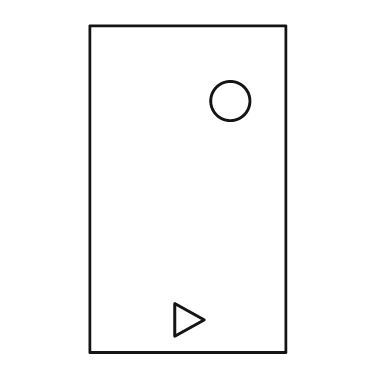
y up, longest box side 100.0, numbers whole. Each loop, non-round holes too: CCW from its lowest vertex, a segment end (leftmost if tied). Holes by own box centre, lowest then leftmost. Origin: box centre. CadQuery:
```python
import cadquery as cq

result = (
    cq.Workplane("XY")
    .moveTo(-30.0, -50.0)
    .lineTo(30.0, -50.0)
    .lineTo(30.0, 50.0)
    .lineTo(-30.0, 50.0)
    .close()
    .moveTo(-4.0, -45.0)
    .lineTo(5.0, -40.0)
    .lineTo(-4.0, -35.0)
    .close()
    .moveTo(13.0, 27.0)
    .circle(6.0)
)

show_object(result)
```